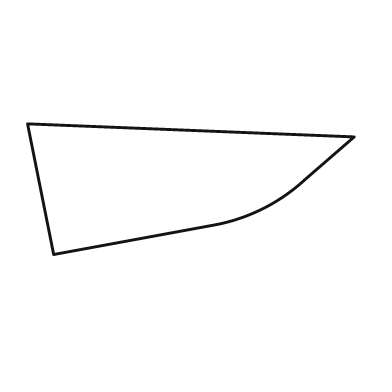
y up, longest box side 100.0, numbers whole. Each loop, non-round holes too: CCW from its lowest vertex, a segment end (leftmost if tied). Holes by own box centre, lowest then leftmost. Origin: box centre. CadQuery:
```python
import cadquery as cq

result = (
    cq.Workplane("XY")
    .moveTo(-42.0, -20.0)
    .lineTo(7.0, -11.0)
    .threePointArc((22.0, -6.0), (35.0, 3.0))
    .lineTo(50.0, 16.0)
    .lineTo(-50.0, 20.0)
    .close()
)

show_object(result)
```